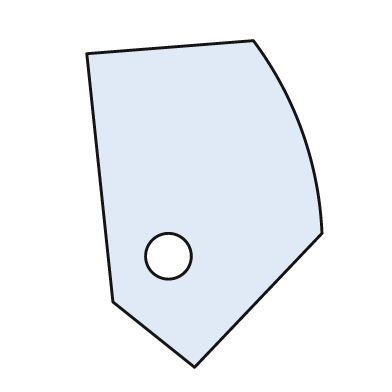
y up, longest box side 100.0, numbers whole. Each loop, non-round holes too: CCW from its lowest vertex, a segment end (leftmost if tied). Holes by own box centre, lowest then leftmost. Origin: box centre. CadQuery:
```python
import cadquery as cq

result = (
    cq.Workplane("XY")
    .moveTo(-3.0, -50.0)
    .lineTo(36.0, -9.0)
    .threePointArc((30.0, 22.0), (15.0, 50.0))
    .lineTo(-36.0, 46.0)
    .lineTo(-28.0, -30.0)
    .close()
    .moveTo(-11.0, -16.0)
    .circle(7.0)
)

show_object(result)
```